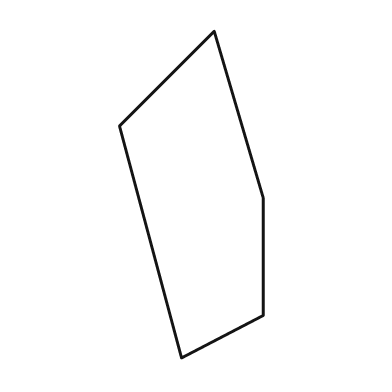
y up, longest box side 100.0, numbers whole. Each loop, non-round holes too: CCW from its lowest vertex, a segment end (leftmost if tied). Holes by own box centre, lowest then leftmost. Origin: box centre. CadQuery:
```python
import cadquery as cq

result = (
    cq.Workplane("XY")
    .moveTo(-3.0, -50.0)
    .lineTo(22.0, -37.0)
    .lineTo(22.0, -1.0)
    .lineTo(7.0, 50.0)
    .lineTo(-22.0, 21.0)
    .close()
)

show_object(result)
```